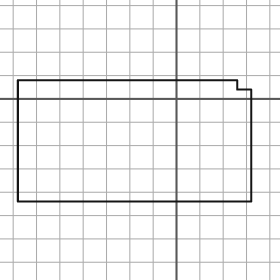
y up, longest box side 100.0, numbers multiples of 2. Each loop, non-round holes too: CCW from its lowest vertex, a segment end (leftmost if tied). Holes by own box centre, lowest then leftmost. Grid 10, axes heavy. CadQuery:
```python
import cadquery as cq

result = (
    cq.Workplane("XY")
    .moveTo(-68.0, -44.0)
    .lineTo(32.0, -44.0)
    .lineTo(32.0, 4.0)
    .lineTo(26.0, 4.0)
    .lineTo(26.0, 8.0)
    .lineTo(-68.0, 8.0)
    .close()
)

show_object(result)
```